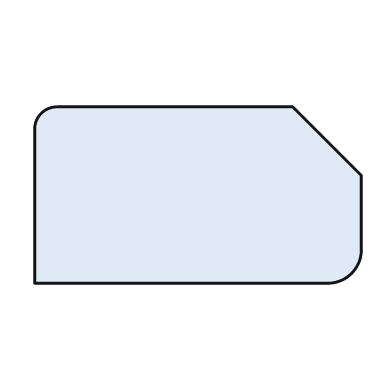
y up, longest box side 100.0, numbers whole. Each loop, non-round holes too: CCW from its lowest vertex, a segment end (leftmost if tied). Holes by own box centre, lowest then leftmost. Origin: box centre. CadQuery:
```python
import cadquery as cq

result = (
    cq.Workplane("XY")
    .moveTo(-50.0, -27.0)
    .lineTo(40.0, -27.0)
    .threePointArc((47.0, -24.0), (50.0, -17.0))
    .lineTo(50.0, 6.0)
    .lineTo(29.0, 27.0)
    .lineTo(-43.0, 27.0)
    .threePointArc((-48.0, 25.0), (-50.0, 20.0))
    .close()
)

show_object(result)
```